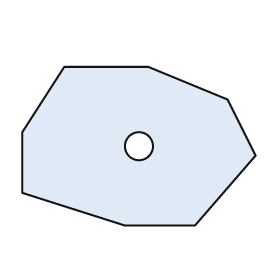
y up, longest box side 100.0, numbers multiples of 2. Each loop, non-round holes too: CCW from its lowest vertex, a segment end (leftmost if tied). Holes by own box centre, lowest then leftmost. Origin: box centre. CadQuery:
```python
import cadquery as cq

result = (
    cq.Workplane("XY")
    .moveTo(-6.0, -34.0)
    .lineTo(24.0, -34.0)
    .lineTo(50.0, -4.0)
    .lineTo(38.0, 20.0)
    .lineTo(4.0, 34.0)
    .lineTo(-32.0, 34.0)
    .lineTo(-50.0, 6.0)
    .lineTo(-50.0, -20.0)
    .close()
    .moveTo(0.0, 0.0)
    .circle(6.0)
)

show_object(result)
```